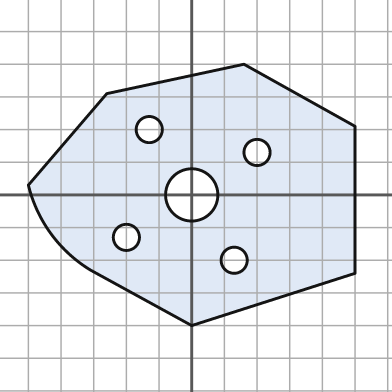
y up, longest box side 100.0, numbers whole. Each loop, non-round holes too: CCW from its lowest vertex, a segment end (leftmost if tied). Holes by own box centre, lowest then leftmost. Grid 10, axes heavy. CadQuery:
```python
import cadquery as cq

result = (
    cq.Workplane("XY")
    .moveTo(0.0, -40.0)
    .lineTo(50.0, -24.0)
    .lineTo(50.0, 21.0)
    .lineTo(16.0, 40.0)
    .lineTo(-26.0, 31.0)
    .lineTo(-50.0, 3.0)
    .threePointArc((-43.0, -12.0), (-31.0, -23.0))
    .close()
    .moveTo(13.0, -20.0)
    .circle(4.0)
    .moveTo(-20.0, -13.0)
    .circle(4.0)
    .moveTo(0.0, 0.0)
    .circle(8.0)
    .moveTo(20.0, 13.0)
    .circle(4.0)
    .moveTo(-13.0, 20.0)
    .circle(4.0)
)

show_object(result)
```